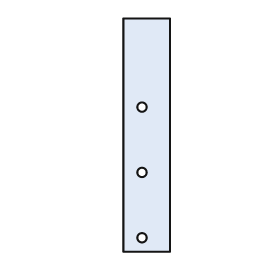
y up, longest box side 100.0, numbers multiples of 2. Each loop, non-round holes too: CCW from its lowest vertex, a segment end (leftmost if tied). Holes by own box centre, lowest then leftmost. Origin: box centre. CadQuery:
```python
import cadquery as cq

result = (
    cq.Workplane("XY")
    .moveTo(-10.0, -50.0)
    .lineTo(10.0, -50.0)
    .lineTo(10.0, 50.0)
    .lineTo(-10.0, 50.0)
    .close()
    .moveTo(-2.0, -44.0)
    .circle(2.0)
    .moveTo(-2.0, -16.0)
    .circle(2.0)
    .moveTo(-2.0, 12.0)
    .circle(2.0)
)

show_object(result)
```